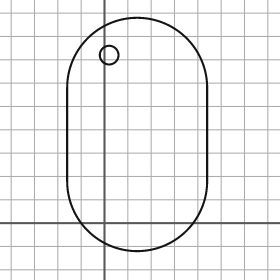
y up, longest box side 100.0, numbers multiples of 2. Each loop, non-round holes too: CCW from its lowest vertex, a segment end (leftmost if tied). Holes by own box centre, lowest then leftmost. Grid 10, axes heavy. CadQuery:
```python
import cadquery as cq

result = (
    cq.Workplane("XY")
    .moveTo(-16.0, 18.0)
    .threePointArc((14.0, -12.0), (44.0, 18.0))
    .lineTo(44.0, 58.0)
    .threePointArc((14.0, 88.0), (-16.0, 58.0))
    .close()
    .moveTo(2.0, 72.0)
    .circle(4.0)
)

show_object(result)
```